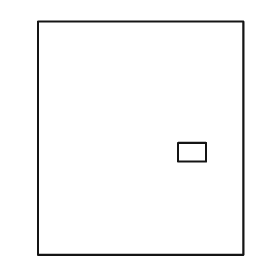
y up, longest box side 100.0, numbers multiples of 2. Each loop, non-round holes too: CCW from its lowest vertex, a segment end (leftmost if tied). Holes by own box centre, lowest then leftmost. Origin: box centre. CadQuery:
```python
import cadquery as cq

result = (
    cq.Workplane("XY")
    .moveTo(-44.0, -50.0)
    .lineTo(44.0, -50.0)
    .lineTo(44.0, 50.0)
    .lineTo(-44.0, 50.0)
    .close()
    .moveTo(16.0, -10.0)
    .lineTo(28.0, -10.0)
    .lineTo(28.0, -2.0)
    .lineTo(16.0, -2.0)
    .close()
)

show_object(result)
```